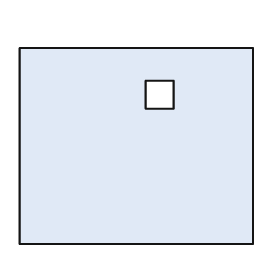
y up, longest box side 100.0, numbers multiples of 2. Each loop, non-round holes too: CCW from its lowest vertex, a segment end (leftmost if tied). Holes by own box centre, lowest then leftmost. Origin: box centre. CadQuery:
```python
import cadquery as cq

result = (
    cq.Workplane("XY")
    .moveTo(-50.0, -42.0)
    .lineTo(50.0, -42.0)
    .lineTo(50.0, 42.0)
    .lineTo(-50.0, 42.0)
    .close()
    .moveTo(4.0, 16.0)
    .lineTo(16.0, 16.0)
    .lineTo(16.0, 28.0)
    .lineTo(4.0, 28.0)
    .close()
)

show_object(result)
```